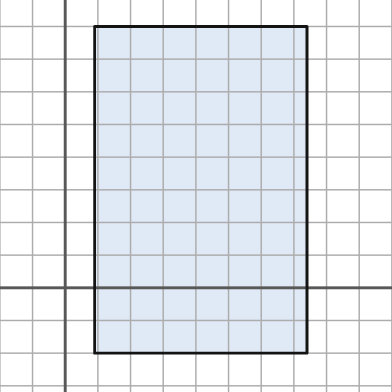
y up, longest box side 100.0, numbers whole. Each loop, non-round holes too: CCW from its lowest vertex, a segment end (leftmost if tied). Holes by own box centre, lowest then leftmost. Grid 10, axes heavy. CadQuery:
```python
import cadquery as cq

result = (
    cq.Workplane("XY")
    .moveTo(9.0, -20.0)
    .lineTo(74.0, -20.0)
    .lineTo(74.0, 80.0)
    .lineTo(9.0, 80.0)
    .close()
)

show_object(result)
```